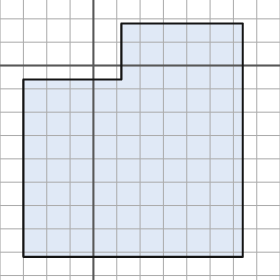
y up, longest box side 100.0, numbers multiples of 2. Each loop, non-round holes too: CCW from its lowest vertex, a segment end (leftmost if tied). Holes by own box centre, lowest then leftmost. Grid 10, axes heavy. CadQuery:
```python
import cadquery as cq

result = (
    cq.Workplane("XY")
    .moveTo(-30.0, -82.0)
    .lineTo(64.0, -82.0)
    .lineTo(64.0, 18.0)
    .lineTo(12.0, 18.0)
    .lineTo(12.0, -6.0)
    .lineTo(-30.0, -6.0)
    .close()
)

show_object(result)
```